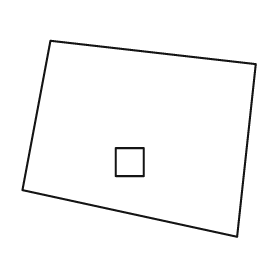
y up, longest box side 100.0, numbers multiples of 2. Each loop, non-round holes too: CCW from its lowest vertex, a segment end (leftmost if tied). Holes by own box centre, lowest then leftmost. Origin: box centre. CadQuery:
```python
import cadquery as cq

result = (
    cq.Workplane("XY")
    .moveTo(42.0, -42.0)
    .lineTo(50.0, 32.0)
    .lineTo(-38.0, 42.0)
    .lineTo(-50.0, -22.0)
    .close()
    .moveTo(-10.0, -16.0)
    .lineTo(2.0, -16.0)
    .lineTo(2.0, -4.0)
    .lineTo(-10.0, -4.0)
    .close()
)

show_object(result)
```